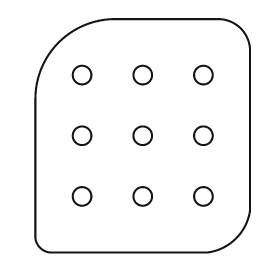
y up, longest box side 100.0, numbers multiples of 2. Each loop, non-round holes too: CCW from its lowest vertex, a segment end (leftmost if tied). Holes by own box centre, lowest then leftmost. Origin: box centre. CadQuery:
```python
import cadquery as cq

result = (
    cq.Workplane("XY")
    .moveTo(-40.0, -50.0)
    .lineTo(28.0, -50.0)
    .threePointArc((40.0, -44.0), (46.0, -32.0))
    .lineTo(46.0, 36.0)
    .threePointArc((42.0, 46.0), (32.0, 50.0))
    .lineTo(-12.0, 50.0)
    .threePointArc((-36.0, 40.0), (-46.0, 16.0))
    .lineTo(-46.0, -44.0)
    .threePointArc((-44.0, -48.0), (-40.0, -50.0))
    .close()
    .moveTo(-26.0, -26.0)
    .circle(4.0)
    .moveTo(0.0, -26.0)
    .circle(4.0)
    .moveTo(26.0, -26.0)
    .circle(4.0)
    .moveTo(-26.0, 0.0)
    .circle(4.0)
    .moveTo(0.0, 0.0)
    .circle(4.0)
    .moveTo(26.0, 0.0)
    .circle(4.0)
    .moveTo(-26.0, 26.0)
    .circle(4.0)
    .moveTo(0.0, 26.0)
    .circle(4.0)
    .moveTo(26.0, 26.0)
    .circle(4.0)
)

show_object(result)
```